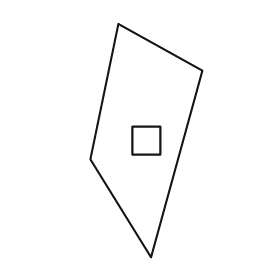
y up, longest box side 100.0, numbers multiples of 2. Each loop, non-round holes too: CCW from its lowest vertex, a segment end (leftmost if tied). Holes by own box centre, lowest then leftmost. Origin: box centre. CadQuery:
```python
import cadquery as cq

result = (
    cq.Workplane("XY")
    .moveTo(2.0, -50.0)
    .lineTo(24.0, 30.0)
    .lineTo(-12.0, 50.0)
    .lineTo(-24.0, -8.0)
    .close()
    .moveTo(-6.0, -6.0)
    .lineTo(6.0, -6.0)
    .lineTo(6.0, 6.0)
    .lineTo(-6.0, 6.0)
    .close()
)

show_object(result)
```